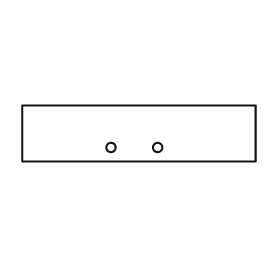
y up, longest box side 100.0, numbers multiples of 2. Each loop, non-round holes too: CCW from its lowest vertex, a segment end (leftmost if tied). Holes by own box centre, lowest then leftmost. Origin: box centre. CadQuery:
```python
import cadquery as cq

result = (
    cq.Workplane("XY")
    .moveTo(-50.0, -12.0)
    .lineTo(50.0, -12.0)
    .lineTo(50.0, 12.0)
    .lineTo(-50.0, 12.0)
    .close()
    .moveTo(-12.0, -6.0)
    .circle(2.0)
    .moveTo(8.0, -6.0)
    .circle(2.0)
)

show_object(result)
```